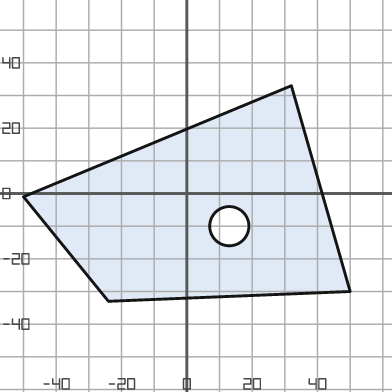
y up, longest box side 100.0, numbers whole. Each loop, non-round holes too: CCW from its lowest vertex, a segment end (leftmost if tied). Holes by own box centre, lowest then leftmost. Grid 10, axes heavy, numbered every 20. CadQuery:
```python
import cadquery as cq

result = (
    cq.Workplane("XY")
    .moveTo(-24.0, -33.0)
    .lineTo(50.0, -30.0)
    .lineTo(32.0, 33.0)
    .lineTo(-50.0, -1.0)
    .close()
    .moveTo(13.0, -10.0)
    .circle(6.0)
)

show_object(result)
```